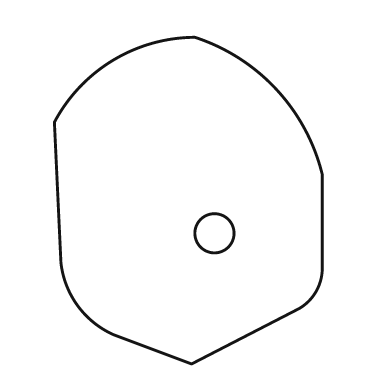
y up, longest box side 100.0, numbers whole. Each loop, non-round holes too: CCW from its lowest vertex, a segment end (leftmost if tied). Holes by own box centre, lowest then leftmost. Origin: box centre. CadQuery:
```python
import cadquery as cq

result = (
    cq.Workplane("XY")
    .moveTo(1.0, -50.0)
    .lineTo(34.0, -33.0)
    .threePointArc((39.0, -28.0), (41.0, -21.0))
    .lineTo(41.0, 8.0)
    .threePointArc((27.0, 34.0), (2.0, 50.0))
    .threePointArc((-23.0, 43.0), (-41.0, 24.0))
    .lineTo(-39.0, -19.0)
    .threePointArc((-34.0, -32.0), (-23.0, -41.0))
    .close()
    .moveTo(8.0, -10.0)
    .circle(6.0)
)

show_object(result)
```